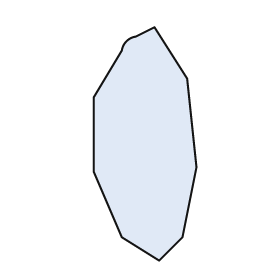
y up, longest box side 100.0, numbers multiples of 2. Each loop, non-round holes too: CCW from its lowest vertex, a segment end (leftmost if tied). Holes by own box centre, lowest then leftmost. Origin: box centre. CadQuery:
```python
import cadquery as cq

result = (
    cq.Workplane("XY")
    .moveTo(6.0, -50.0)
    .lineTo(16.0, -40.0)
    .lineTo(22.0, -10.0)
    .lineTo(18.0, 28.0)
    .lineTo(4.0, 50.0)
    .lineTo(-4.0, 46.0)
    .threePointArc((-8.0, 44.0), (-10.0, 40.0))
    .lineTo(-22.0, 20.0)
    .lineTo(-22.0, -12.0)
    .lineTo(-10.0, -40.0)
    .close()
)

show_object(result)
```